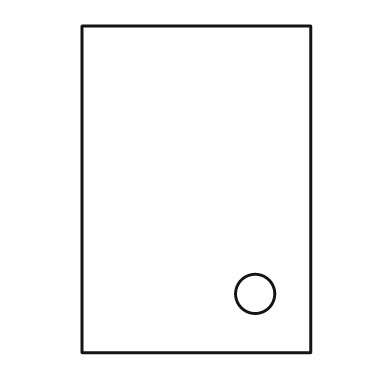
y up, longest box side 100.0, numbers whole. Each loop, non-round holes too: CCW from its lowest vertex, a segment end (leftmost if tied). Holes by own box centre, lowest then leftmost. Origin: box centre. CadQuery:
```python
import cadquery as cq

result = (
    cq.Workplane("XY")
    .moveTo(-35.0, -50.0)
    .lineTo(35.0, -50.0)
    .lineTo(35.0, 50.0)
    .lineTo(-35.0, 50.0)
    .close()
    .moveTo(18.0, -32.0)
    .circle(6.0)
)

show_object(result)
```